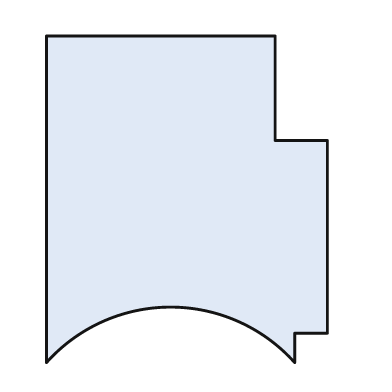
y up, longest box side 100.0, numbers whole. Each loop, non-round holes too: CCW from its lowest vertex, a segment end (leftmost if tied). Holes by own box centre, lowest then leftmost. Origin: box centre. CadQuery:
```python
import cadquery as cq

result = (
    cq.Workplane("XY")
    .moveTo(-43.0, -50.0)
    .threePointArc((-5.0, -33.0), (33.0, -50.0))
    .lineTo(33.0, -41.0)
    .lineTo(43.0, -41.0)
    .lineTo(43.0, 18.0)
    .lineTo(27.0, 18.0)
    .lineTo(27.0, 50.0)
    .lineTo(-43.0, 50.0)
    .close()
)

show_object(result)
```